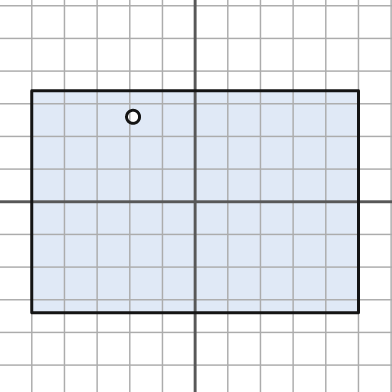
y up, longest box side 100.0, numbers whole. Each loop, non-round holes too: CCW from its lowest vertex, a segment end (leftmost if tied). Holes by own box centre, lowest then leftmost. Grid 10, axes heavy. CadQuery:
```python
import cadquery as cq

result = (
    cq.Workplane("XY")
    .moveTo(-50.0, -34.0)
    .lineTo(50.0, -34.0)
    .lineTo(50.0, 34.0)
    .lineTo(-50.0, 34.0)
    .close()
    .moveTo(-19.0, 26.0)
    .circle(2.0)
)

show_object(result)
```